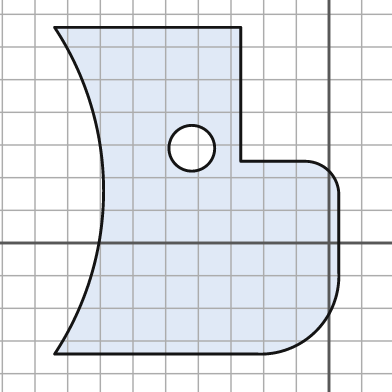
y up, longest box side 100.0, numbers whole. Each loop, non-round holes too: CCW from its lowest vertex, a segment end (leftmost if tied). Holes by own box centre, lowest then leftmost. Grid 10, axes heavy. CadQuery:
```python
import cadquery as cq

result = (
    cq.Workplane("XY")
    .moveTo(-84.0, -34.0)
    .lineTo(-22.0, -34.0)
    .threePointArc((-4.0, -27.0), (3.0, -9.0))
    .lineTo(3.0, 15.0)
    .threePointArc((0.0, 22.0), (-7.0, 25.0))
    .lineTo(-27.0, 25.0)
    .lineTo(-27.0, 66.0)
    .lineTo(-84.0, 66.0)
    .threePointArc((-69.0, 16.0), (-84.0, -34.0))
    .close()
    .moveTo(-42.0, 29.0)
    .circle(7.0)
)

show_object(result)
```